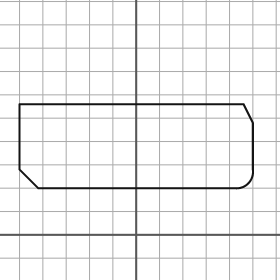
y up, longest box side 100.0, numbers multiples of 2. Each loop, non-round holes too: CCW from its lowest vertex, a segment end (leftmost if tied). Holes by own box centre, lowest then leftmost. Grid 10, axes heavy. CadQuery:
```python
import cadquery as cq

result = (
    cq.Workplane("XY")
    .moveTo(-42.0, 20.0)
    .lineTo(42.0, 20.0)
    .threePointArc((48.0, 22.0), (50.0, 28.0))
    .lineTo(50.0, 48.0)
    .lineTo(46.0, 56.0)
    .lineTo(-50.0, 56.0)
    .lineTo(-50.0, 28.0)
    .close()
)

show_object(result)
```